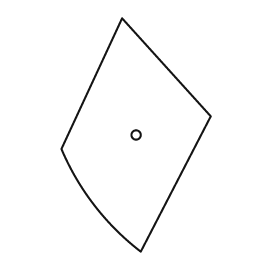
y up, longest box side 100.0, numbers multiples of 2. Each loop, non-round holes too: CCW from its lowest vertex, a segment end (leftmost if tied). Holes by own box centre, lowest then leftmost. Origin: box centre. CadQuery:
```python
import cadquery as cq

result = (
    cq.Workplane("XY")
    .moveTo(2.0, -50.0)
    .lineTo(32.0, 8.0)
    .lineTo(-6.0, 50.0)
    .lineTo(-32.0, -6.0)
    .threePointArc((-18.0, -30.0), (2.0, -50.0))
    .close()
    .moveTo(0.0, 0.0)
    .circle(2.0)
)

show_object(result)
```